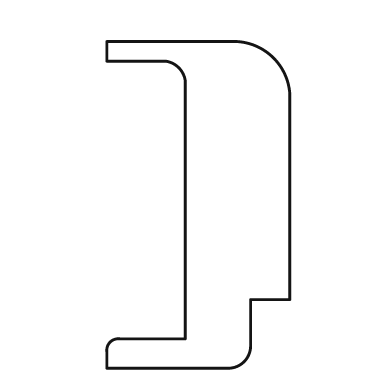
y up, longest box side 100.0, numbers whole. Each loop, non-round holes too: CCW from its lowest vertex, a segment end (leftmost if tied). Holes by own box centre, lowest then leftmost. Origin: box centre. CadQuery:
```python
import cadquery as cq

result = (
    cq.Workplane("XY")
    .moveTo(-28.0, -50.0)
    .lineTo(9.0, -50.0)
    .threePointArc((14.0, -48.0), (16.0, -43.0))
    .lineTo(16.0, -29.0)
    .lineTo(28.0, -29.0)
    .lineTo(28.0, 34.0)
    .threePointArc((23.0, 45.0), (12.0, 50.0))
    .lineTo(-28.0, 50.0)
    .lineTo(-28.0, 44.0)
    .lineTo(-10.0, 44.0)
    .threePointArc((-6.0, 42.0), (-4.0, 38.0))
    .lineTo(-4.0, -41.0)
    .lineTo(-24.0, -41.0)
    .threePointArc((-27.0, -42.0), (-28.0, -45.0))
    .close()
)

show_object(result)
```